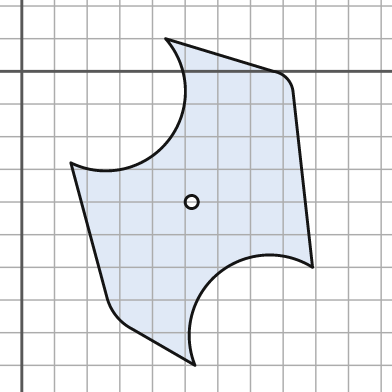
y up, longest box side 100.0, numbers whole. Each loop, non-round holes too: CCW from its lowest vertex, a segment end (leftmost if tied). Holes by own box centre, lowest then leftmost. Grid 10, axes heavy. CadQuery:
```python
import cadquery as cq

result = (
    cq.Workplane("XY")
    .moveTo(53.0, -90.0)
    .threePointArc((60.0, -62.0), (89.0, -60.0))
    .lineTo(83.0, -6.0)
    .threePointArc((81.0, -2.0), (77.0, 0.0))
    .lineTo(44.0, 10.0)
    .threePointArc((45.0, -21.0), (15.0, -28.0))
    .lineTo(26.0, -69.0)
    .threePointArc((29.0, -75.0), (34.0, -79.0))
    .close()
    .moveTo(52.0, -40.0)
    .circle(2.0)
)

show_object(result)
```